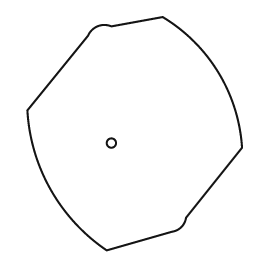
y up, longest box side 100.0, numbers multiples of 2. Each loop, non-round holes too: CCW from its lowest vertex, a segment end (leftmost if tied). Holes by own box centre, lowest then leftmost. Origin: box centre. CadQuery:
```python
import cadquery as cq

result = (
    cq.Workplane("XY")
    .moveTo(-12.0, -50.0)
    .lineTo(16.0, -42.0)
    .threePointArc((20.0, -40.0), (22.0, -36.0))
    .lineTo(46.0, -6.0)
    .threePointArc((36.0, 26.0), (12.0, 50.0))
    .lineTo(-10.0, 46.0)
    .threePointArc((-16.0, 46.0), (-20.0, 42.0))
    .lineTo(-46.0, 10.0)
    .threePointArc((-36.0, -24.0), (-12.0, -50.0))
    .close()
    .moveTo(-10.0, -4.0)
    .circle(2.0)
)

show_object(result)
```